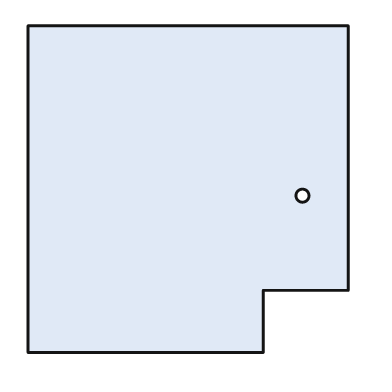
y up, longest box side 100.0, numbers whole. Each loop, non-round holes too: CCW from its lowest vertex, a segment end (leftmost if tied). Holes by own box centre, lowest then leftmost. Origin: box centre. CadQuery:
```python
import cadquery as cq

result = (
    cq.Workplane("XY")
    .moveTo(-49.0, -50.0)
    .lineTo(23.0, -50.0)
    .lineTo(23.0, -31.0)
    .lineTo(49.0, -31.0)
    .lineTo(49.0, 50.0)
    .lineTo(-49.0, 50.0)
    .close()
    .moveTo(35.0, -2.0)
    .circle(2.0)
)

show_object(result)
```